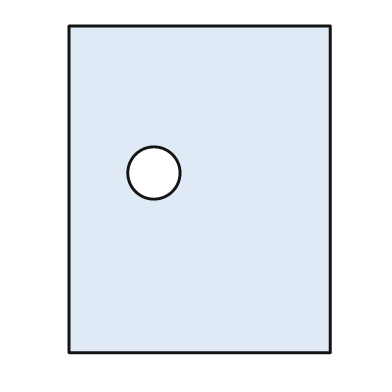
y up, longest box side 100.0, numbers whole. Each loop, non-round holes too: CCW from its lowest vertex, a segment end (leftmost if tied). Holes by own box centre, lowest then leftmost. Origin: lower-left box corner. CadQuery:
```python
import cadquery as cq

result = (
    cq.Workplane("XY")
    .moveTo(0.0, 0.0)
    .lineTo(80.0, 0.0)
    .lineTo(80.0, 100.0)
    .lineTo(0.0, 100.0)
    .close()
    .moveTo(26.0, 55.0)
    .circle(8.0)
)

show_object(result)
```